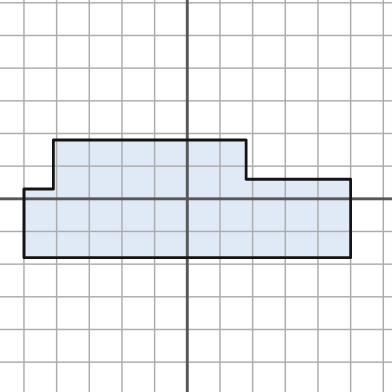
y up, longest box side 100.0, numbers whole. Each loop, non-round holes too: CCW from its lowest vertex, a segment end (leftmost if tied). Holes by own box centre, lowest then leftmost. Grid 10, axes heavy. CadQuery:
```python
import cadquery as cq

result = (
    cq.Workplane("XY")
    .moveTo(-50.0, -18.0)
    .lineTo(50.0, -18.0)
    .lineTo(50.0, 6.0)
    .lineTo(18.0, 6.0)
    .lineTo(18.0, 18.0)
    .lineTo(-41.0, 18.0)
    .lineTo(-41.0, 3.0)
    .lineTo(-50.0, 3.0)
    .close()
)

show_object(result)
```